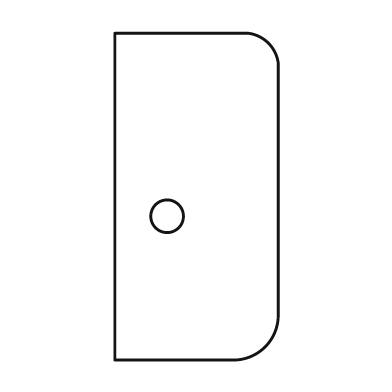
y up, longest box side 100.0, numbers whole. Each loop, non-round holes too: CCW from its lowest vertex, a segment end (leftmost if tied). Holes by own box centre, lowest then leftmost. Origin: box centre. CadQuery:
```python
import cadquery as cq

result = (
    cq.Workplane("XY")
    .moveTo(-25.0, -50.0)
    .lineTo(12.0, -50.0)
    .threePointArc((21.0, -46.0), (25.0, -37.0))
    .lineTo(25.0, 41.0)
    .threePointArc((22.0, 47.0), (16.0, 50.0))
    .lineTo(-25.0, 50.0)
    .close()
    .moveTo(-9.0, -6.0)
    .circle(5.0)
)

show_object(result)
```